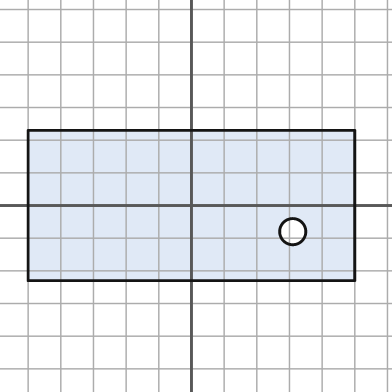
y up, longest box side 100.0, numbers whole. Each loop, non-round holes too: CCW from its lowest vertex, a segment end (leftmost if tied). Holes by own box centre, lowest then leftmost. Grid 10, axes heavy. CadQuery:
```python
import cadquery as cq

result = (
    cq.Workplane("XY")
    .moveTo(-50.0, -23.0)
    .lineTo(50.0, -23.0)
    .lineTo(50.0, 23.0)
    .lineTo(-50.0, 23.0)
    .close()
    .moveTo(31.0, -8.0)
    .circle(4.0)
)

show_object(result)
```